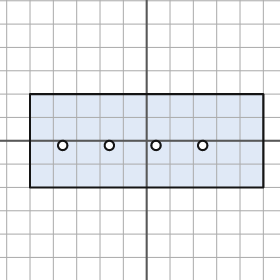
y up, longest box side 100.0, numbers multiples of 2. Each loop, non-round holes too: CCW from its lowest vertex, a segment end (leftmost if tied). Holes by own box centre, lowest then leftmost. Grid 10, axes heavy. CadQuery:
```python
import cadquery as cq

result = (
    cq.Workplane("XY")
    .moveTo(-50.0, -20.0)
    .lineTo(50.0, -20.0)
    .lineTo(50.0, 20.0)
    .lineTo(-50.0, 20.0)
    .close()
    .moveTo(-36.0, -2.0)
    .circle(2.0)
    .moveTo(-16.0, -2.0)
    .circle(2.0)
    .moveTo(4.0, -2.0)
    .circle(2.0)
    .moveTo(24.0, -2.0)
    .circle(2.0)
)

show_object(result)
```